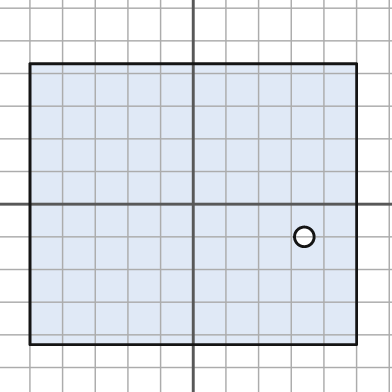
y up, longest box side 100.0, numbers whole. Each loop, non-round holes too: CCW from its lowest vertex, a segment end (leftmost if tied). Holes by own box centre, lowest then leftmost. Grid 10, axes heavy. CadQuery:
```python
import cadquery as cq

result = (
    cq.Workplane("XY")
    .moveTo(-50.0, -43.0)
    .lineTo(50.0, -43.0)
    .lineTo(50.0, 43.0)
    .lineTo(-50.0, 43.0)
    .close()
    .moveTo(34.0, -10.0)
    .circle(3.0)
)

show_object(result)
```